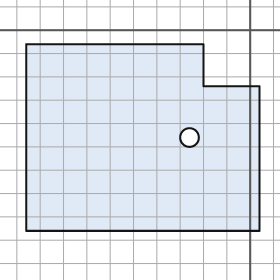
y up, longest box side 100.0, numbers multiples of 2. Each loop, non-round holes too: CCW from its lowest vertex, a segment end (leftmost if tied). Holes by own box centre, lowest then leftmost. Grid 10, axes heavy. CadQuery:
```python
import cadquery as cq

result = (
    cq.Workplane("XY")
    .moveTo(-96.0, -86.0)
    .lineTo(4.0, -86.0)
    .lineTo(4.0, -24.0)
    .lineTo(-20.0, -24.0)
    .lineTo(-20.0, -6.0)
    .lineTo(-96.0, -6.0)
    .close()
    .moveTo(-26.0, -46.0)
    .circle(4.0)
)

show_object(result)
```